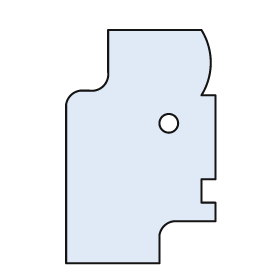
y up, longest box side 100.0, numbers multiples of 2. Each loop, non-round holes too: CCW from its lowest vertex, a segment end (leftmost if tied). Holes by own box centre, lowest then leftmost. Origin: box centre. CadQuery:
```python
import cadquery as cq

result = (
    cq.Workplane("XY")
    .moveTo(-32.0, -50.0)
    .lineTo(8.0, -50.0)
    .lineTo(8.0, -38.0)
    .threePointArc((10.0, -34.0), (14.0, -32.0))
    .lineTo(32.0, -32.0)
    .lineTo(32.0, -24.0)
    .lineTo(26.0, -24.0)
    .lineTo(26.0, -14.0)
    .lineTo(32.0, -14.0)
    .lineTo(32.0, 22.0)
    .lineTo(26.0, 22.0)
    .threePointArc((30.0, 36.0), (26.0, 50.0))
    .lineTo(-14.0, 50.0)
    .lineTo(-14.0, 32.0)
    .threePointArc((-16.0, 26.0), (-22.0, 24.0))
    .lineTo(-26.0, 24.0)
    .threePointArc((-30.0, 22.0), (-32.0, 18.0))
    .close()
    .moveTo(12.0, 10.0)
    .circle(4.0)
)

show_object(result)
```